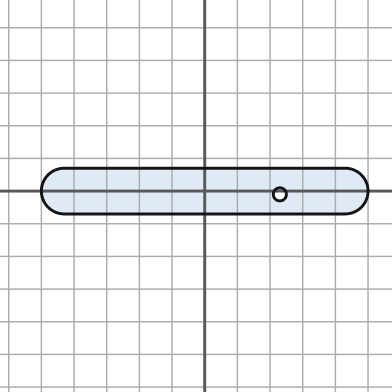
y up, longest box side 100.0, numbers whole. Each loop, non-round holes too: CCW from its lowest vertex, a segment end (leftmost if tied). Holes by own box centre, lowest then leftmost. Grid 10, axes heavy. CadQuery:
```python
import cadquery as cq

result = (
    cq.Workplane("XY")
    .moveTo(-43.0, -7.0)
    .lineTo(43.0, -7.0)
    .threePointArc((50.0, 0.0), (43.0, 7.0))
    .lineTo(-43.0, 7.0)
    .threePointArc((-50.0, 0.0), (-43.0, -7.0))
    .close()
    .moveTo(23.0, -1.0)
    .circle(2.0)
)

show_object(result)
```